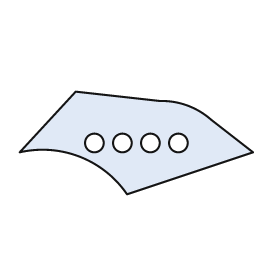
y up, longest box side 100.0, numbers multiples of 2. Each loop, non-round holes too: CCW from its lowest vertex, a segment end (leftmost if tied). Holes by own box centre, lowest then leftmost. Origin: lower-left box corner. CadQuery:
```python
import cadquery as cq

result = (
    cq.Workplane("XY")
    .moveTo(46.0, 0.0)
    .lineTo(100.0, 18.0)
    .lineTo(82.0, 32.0)
    .threePointArc((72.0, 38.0), (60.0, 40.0))
    .lineTo(24.0, 44.0)
    .lineTo(0.0, 18.0)
    .threePointArc((26.0, 16.0), (46.0, 0.0))
    .close()
    .moveTo(32.0, 22.0)
    .circle(4.0)
    .moveTo(44.0, 22.0)
    .circle(4.0)
    .moveTo(56.0, 22.0)
    .circle(4.0)
    .moveTo(68.0, 22.0)
    .circle(4.0)
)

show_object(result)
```